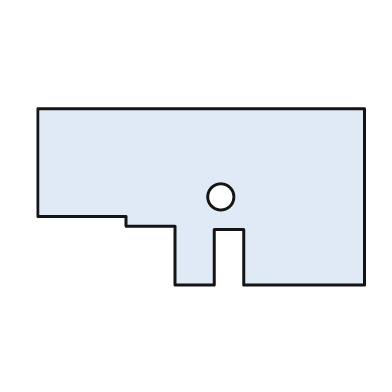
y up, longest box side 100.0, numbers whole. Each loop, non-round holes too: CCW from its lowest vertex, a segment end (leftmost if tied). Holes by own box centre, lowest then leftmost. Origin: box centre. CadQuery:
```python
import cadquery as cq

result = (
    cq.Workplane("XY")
    .moveTo(-8.0, -27.0)
    .lineTo(4.0, -27.0)
    .lineTo(4.0, -10.0)
    .lineTo(13.0, -10.0)
    .lineTo(13.0, -27.0)
    .lineTo(50.0, -27.0)
    .lineTo(50.0, 27.0)
    .lineTo(-50.0, 27.0)
    .lineTo(-50.0, -6.0)
    .lineTo(-23.0, -6.0)
    .lineTo(-23.0, -9.0)
    .lineTo(-8.0, -9.0)
    .close()
    .moveTo(6.0, 0.0)
    .circle(4.0)
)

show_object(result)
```